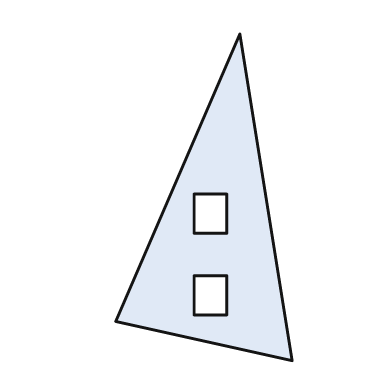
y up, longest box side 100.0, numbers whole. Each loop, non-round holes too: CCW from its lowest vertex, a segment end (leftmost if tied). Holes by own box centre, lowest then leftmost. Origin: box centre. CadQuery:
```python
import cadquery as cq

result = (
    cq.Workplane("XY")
    .moveTo(27.0, -50.0)
    .lineTo(11.0, 50.0)
    .lineTo(-27.0, -38.0)
    .close()
    .moveTo(-3.0, -36.0)
    .lineTo(7.0, -36.0)
    .lineTo(7.0, -24.0)
    .lineTo(-3.0, -24.0)
    .close()
    .moveTo(-3.0, -11.0)
    .lineTo(7.0, -11.0)
    .lineTo(7.0, 1.0)
    .lineTo(-3.0, 1.0)
    .close()
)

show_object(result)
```